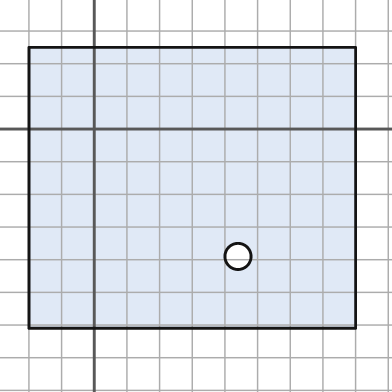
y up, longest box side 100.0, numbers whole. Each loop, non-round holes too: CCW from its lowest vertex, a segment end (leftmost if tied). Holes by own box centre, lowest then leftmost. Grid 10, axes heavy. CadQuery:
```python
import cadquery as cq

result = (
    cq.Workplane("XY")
    .moveTo(-20.0, -61.0)
    .lineTo(80.0, -61.0)
    .lineTo(80.0, 25.0)
    .lineTo(-20.0, 25.0)
    .close()
    .moveTo(44.0, -39.0)
    .circle(4.0)
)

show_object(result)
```